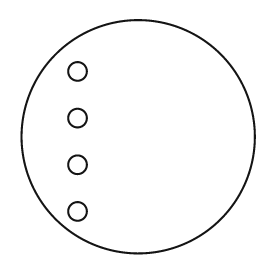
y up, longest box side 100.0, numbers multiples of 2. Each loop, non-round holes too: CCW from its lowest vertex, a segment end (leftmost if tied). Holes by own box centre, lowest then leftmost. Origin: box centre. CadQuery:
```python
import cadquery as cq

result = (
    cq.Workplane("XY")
    .moveTo(0.0, 0.0)
    .circle(50.0)
    .moveTo(-26.0, -32.0)
    .circle(4.0)
    .moveTo(-26.0, -12.0)
    .circle(4.0)
    .moveTo(-26.0, 8.0)
    .circle(4.0)
    .moveTo(-26.0, 28.0)
    .circle(4.0)
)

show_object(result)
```